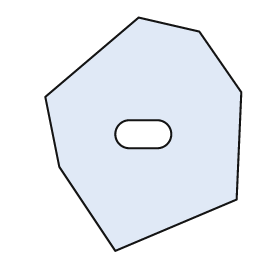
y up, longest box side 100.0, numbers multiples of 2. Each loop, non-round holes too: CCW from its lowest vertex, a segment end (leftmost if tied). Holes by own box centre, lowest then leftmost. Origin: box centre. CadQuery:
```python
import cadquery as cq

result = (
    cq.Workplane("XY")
    .moveTo(-12.0, -50.0)
    .lineTo(40.0, -28.0)
    .lineTo(42.0, 18.0)
    .lineTo(24.0, 44.0)
    .lineTo(-2.0, 50.0)
    .lineTo(-42.0, 16.0)
    .lineTo(-36.0, -14.0)
    .close()
    .moveTo(-6.0, -6.0)
    .lineTo(6.0, -6.0)
    .threePointArc((12.0, 0.0), (6.0, 6.0))
    .lineTo(-6.0, 6.0)
    .threePointArc((-12.0, 0.0), (-6.0, -6.0))
    .close()
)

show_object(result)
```